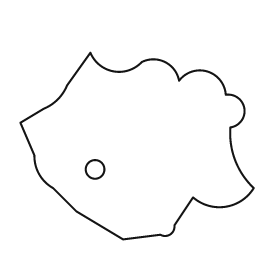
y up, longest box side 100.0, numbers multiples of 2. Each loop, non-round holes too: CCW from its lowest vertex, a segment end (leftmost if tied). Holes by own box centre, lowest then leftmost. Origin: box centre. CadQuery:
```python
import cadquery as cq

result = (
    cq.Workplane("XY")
    .moveTo(-6.0, -40.0)
    .lineTo(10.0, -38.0)
    .threePointArc((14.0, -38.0), (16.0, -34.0))
    .lineTo(24.0, -22.0)
    .threePointArc((38.0, -26.0), (50.0, -18.0))
    .threePointArc((42.0, -6.0), (40.0, 8.0))
    .threePointArc((46.0, 16.0), (38.0, 22.0))
    .threePointArc((30.0, 32.0), (18.0, 28.0))
    .threePointArc((12.0, 36.0), (2.0, 36.0))
    .threePointArc((-10.0, 32.0), (-20.0, 40.0))
    .lineTo(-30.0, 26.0)
    .threePointArc((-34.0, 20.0), (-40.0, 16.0))
    .lineTo(-50.0, 10.0)
    .lineTo(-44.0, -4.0)
    .threePointArc((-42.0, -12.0), (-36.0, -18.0))
    .lineTo(-26.0, -28.0)
    .close()
    .moveTo(-18.0, -10.0)
    .circle(4.0)
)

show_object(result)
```